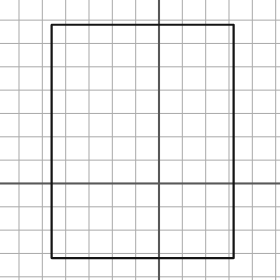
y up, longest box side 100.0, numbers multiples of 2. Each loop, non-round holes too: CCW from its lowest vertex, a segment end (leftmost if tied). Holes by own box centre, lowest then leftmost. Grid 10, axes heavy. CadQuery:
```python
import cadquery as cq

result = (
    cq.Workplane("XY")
    .moveTo(-46.0, -32.0)
    .lineTo(32.0, -32.0)
    .lineTo(32.0, 68.0)
    .lineTo(-46.0, 68.0)
    .close()
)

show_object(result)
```